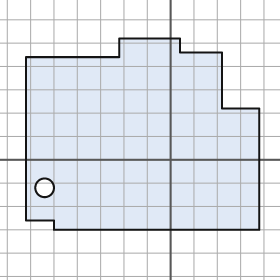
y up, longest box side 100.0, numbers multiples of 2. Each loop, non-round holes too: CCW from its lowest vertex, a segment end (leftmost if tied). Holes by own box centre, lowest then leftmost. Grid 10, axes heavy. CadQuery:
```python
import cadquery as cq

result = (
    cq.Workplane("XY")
    .moveTo(-50.0, -30.0)
    .lineTo(38.0, -30.0)
    .lineTo(38.0, 22.0)
    .lineTo(22.0, 22.0)
    .lineTo(22.0, 46.0)
    .lineTo(4.0, 46.0)
    .lineTo(4.0, 52.0)
    .lineTo(-22.0, 52.0)
    .lineTo(-22.0, 44.0)
    .lineTo(-62.0, 44.0)
    .lineTo(-62.0, -26.0)
    .lineTo(-50.0, -26.0)
    .close()
    .moveTo(-54.0, -12.0)
    .circle(4.0)
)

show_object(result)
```